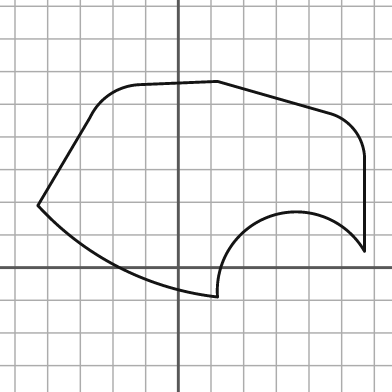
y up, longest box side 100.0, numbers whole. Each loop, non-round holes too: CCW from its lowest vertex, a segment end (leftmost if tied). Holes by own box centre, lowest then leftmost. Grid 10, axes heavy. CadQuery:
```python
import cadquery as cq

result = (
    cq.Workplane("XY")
    .moveTo(12.0, -9.0)
    .threePointArc((29.0, 16.0), (57.0, 5.0))
    .lineTo(57.0, 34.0)
    .threePointArc((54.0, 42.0), (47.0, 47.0))
    .lineTo(12.0, 57.0)
    .lineTo(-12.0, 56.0)
    .threePointArc((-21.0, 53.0), (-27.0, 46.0))
    .lineTo(-43.0, 19.0)
    .threePointArc((-18.0, 0.0), (12.0, -9.0))
    .close()
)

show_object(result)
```